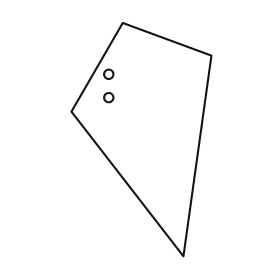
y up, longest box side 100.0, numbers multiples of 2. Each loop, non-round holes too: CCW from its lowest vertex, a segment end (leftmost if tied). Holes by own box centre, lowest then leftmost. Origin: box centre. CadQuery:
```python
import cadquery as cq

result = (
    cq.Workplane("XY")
    .moveTo(18.0, -50.0)
    .lineTo(30.0, 36.0)
    .lineTo(-8.0, 50.0)
    .lineTo(-30.0, 12.0)
    .close()
    .moveTo(-14.0, 18.0)
    .circle(2.0)
    .moveTo(-14.0, 28.0)
    .circle(2.0)
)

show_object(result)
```